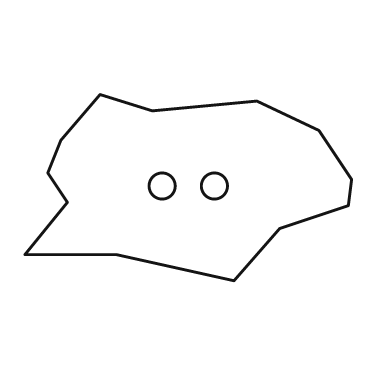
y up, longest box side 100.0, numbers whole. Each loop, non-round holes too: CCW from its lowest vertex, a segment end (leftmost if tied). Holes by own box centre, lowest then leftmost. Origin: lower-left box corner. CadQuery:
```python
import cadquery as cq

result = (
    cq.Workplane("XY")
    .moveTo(64.0, 0.0)
    .lineTo(78.0, 16.0)
    .lineTo(99.0, 23.0)
    .lineTo(100.0, 31.0)
    .lineTo(90.0, 46.0)
    .lineTo(71.0, 55.0)
    .lineTo(39.0, 52.0)
    .lineTo(23.0, 57.0)
    .lineTo(11.0, 43.0)
    .lineTo(7.0, 33.0)
    .lineTo(13.0, 24.0)
    .lineTo(0.0, 8.0)
    .lineTo(28.0, 8.0)
    .close()
    .moveTo(42.0, 29.0)
    .circle(4.0)
    .moveTo(58.0, 29.0)
    .circle(4.0)
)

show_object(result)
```